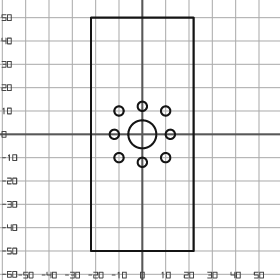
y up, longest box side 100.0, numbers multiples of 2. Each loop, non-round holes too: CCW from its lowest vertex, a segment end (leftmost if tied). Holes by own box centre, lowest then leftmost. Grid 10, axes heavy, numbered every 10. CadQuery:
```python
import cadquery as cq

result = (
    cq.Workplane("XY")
    .moveTo(-22.0, -50.0)
    .lineTo(22.0, -50.0)
    .lineTo(22.0, 50.0)
    .lineTo(-22.0, 50.0)
    .close()
    .moveTo(0.0, -12.0)
    .circle(2.0)
    .moveTo(-10.0, -10.0)
    .circle(2.0)
    .moveTo(10.0, -10.0)
    .circle(2.0)
    .moveTo(-12.0, 0.0)
    .circle(2.0)
    .moveTo(0.0, 0.0)
    .circle(6.0)
    .moveTo(12.0, 0.0)
    .circle(2.0)
    .moveTo(-10.0, 10.0)
    .circle(2.0)
    .moveTo(10.0, 10.0)
    .circle(2.0)
    .moveTo(0.0, 12.0)
    .circle(2.0)
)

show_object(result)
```